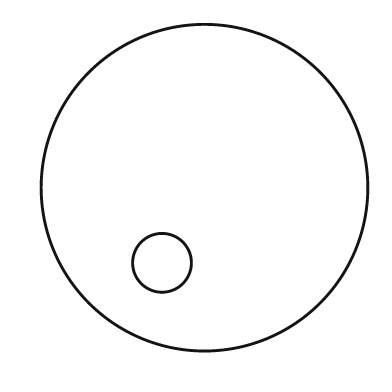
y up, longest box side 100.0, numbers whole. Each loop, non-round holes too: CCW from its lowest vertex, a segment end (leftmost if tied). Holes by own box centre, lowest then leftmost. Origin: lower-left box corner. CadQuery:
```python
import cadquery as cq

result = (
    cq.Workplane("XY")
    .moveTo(50.0, 50.0)
    .circle(50.0)
    .moveTo(37.0, 27.0)
    .circle(9.0)
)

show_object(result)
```